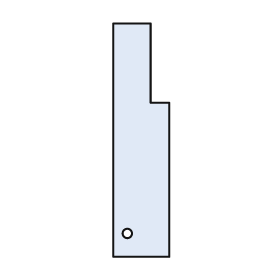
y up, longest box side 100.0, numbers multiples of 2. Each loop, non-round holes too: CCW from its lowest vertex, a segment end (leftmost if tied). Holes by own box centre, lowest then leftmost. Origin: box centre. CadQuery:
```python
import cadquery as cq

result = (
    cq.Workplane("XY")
    .moveTo(-12.0, -50.0)
    .lineTo(12.0, -50.0)
    .lineTo(12.0, 16.0)
    .lineTo(4.0, 16.0)
    .lineTo(4.0, 50.0)
    .lineTo(-12.0, 50.0)
    .close()
    .moveTo(-6.0, -40.0)
    .circle(2.0)
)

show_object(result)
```